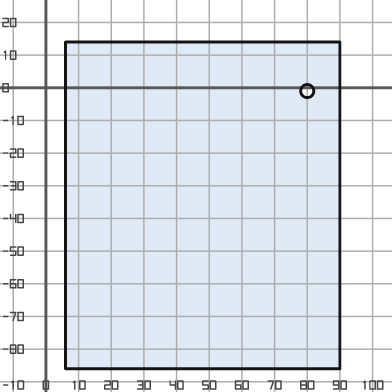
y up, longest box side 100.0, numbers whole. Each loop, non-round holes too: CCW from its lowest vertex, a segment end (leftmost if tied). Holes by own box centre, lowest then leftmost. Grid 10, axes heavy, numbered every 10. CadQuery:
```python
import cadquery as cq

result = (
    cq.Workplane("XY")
    .moveTo(6.0, -86.0)
    .lineTo(90.0, -86.0)
    .lineTo(90.0, 14.0)
    .lineTo(6.0, 14.0)
    .close()
    .moveTo(80.0, -1.0)
    .circle(2.0)
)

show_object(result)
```